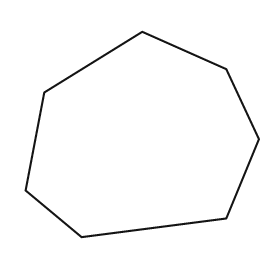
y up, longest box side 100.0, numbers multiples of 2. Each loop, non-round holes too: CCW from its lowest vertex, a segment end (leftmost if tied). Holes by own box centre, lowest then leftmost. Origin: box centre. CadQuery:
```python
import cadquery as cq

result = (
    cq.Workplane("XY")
    .moveTo(-26.0, -44.0)
    .lineTo(36.0, -36.0)
    .lineTo(50.0, -2.0)
    .lineTo(36.0, 28.0)
    .lineTo(0.0, 44.0)
    .lineTo(-42.0, 18.0)
    .lineTo(-50.0, -24.0)
    .close()
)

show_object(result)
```